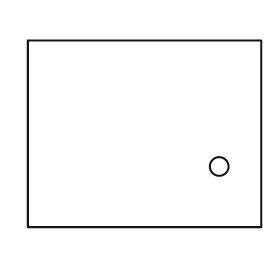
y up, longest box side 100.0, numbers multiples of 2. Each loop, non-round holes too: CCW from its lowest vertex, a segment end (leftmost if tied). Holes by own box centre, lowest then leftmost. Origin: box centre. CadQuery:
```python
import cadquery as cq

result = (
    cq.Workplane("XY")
    .moveTo(-50.0, -40.0)
    .lineTo(50.0, -40.0)
    .lineTo(50.0, 40.0)
    .lineTo(-50.0, 40.0)
    .close()
    .moveTo(32.0, -14.0)
    .circle(4.0)
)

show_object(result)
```